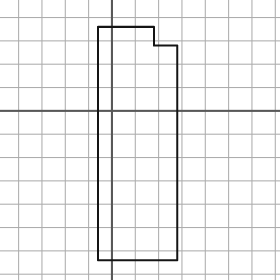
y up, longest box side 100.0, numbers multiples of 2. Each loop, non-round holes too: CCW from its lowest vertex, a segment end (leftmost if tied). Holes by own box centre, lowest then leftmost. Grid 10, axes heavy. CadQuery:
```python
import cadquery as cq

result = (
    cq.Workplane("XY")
    .moveTo(-6.0, -64.0)
    .lineTo(28.0, -64.0)
    .lineTo(28.0, 28.0)
    .lineTo(18.0, 28.0)
    .lineTo(18.0, 36.0)
    .lineTo(-6.0, 36.0)
    .close()
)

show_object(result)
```